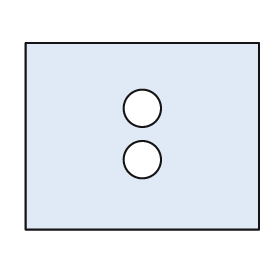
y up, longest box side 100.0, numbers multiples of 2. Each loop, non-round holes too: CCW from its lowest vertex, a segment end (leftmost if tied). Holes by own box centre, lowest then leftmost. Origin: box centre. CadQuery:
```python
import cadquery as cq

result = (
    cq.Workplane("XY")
    .moveTo(-50.0, -40.0)
    .lineTo(50.0, -40.0)
    .lineTo(50.0, 40.0)
    .lineTo(-50.0, 40.0)
    .close()
    .moveTo(0.0, -10.0)
    .circle(8.0)
    .moveTo(0.0, 12.0)
    .circle(8.0)
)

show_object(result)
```